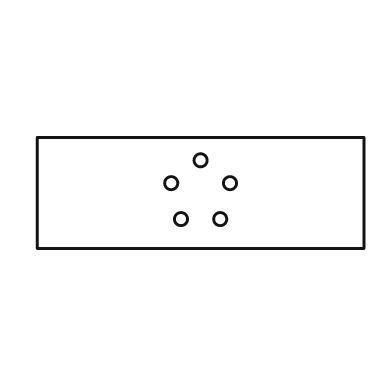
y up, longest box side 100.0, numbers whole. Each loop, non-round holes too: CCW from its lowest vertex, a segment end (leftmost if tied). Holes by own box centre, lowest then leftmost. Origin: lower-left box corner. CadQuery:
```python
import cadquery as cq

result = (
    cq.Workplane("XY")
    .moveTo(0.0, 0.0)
    .lineTo(100.0, 0.0)
    .lineTo(100.0, 34.0)
    .lineTo(0.0, 34.0)
    .close()
    .moveTo(44.0, 9.0)
    .circle(2.0)
    .moveTo(56.0, 9.0)
    .circle(2.0)
    .moveTo(41.0, 20.0)
    .circle(2.0)
    .moveTo(59.0, 20.0)
    .circle(2.0)
    .moveTo(50.0, 27.0)
    .circle(2.0)
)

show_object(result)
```